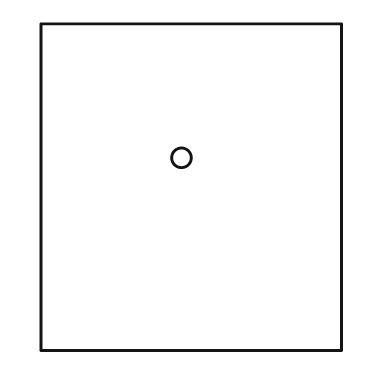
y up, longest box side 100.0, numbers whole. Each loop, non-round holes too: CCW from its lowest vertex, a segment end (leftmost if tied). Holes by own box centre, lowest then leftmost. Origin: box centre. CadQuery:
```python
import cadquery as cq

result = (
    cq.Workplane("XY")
    .moveTo(-46.0, -50.0)
    .lineTo(46.0, -50.0)
    .lineTo(46.0, 50.0)
    .lineTo(-46.0, 50.0)
    .close()
    .moveTo(-3.0, 9.0)
    .circle(3.0)
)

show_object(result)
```